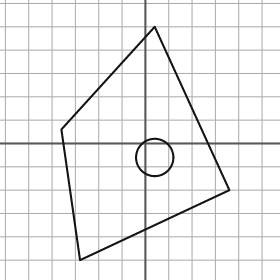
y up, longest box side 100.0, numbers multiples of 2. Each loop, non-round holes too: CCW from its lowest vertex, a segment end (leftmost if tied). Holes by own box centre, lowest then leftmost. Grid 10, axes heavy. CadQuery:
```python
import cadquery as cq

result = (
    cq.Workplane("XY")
    .moveTo(-28.0, -50.0)
    .lineTo(36.0, -20.0)
    .lineTo(4.0, 50.0)
    .lineTo(-36.0, 6.0)
    .close()
    .moveTo(4.0, -6.0)
    .circle(8.0)
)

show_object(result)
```